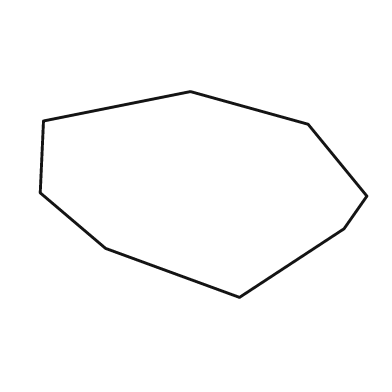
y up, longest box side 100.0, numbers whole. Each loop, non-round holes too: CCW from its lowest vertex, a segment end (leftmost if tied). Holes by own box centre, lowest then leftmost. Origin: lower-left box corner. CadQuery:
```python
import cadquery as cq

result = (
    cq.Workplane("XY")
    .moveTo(61.0, 0.0)
    .lineTo(93.0, 21.0)
    .lineTo(100.0, 31.0)
    .lineTo(82.0, 53.0)
    .lineTo(46.0, 63.0)
    .lineTo(1.0, 54.0)
    .lineTo(0.0, 32.0)
    .lineTo(20.0, 15.0)
    .close()
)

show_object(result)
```